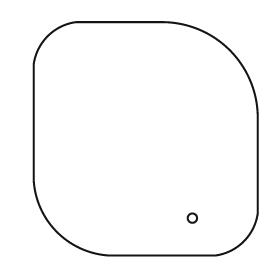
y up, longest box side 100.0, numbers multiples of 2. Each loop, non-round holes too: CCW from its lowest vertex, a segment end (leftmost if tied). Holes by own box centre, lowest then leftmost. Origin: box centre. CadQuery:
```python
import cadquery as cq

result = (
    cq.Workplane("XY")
    .moveTo(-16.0, -50.0)
    .lineTo(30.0, -50.0)
    .threePointArc((42.0, -44.0), (48.0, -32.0))
    .lineTo(48.0, 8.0)
    .threePointArc((36.0, 38.0), (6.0, 50.0))
    .lineTo(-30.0, 50.0)
    .threePointArc((-42.0, 44.0), (-48.0, 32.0))
    .lineTo(-48.0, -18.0)
    .threePointArc((-38.0, -40.0), (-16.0, -50.0))
    .close()
    .moveTo(20.0, -34.0)
    .circle(2.0)
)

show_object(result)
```